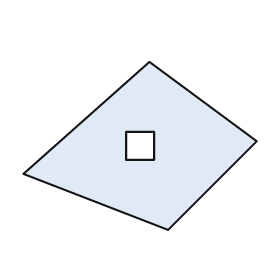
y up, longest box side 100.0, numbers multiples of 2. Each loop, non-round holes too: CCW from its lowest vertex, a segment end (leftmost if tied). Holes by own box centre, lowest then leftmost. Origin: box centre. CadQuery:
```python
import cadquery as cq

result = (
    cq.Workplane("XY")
    .moveTo(12.0, -36.0)
    .lineTo(50.0, 2.0)
    .lineTo(4.0, 36.0)
    .lineTo(-50.0, -12.0)
    .close()
    .moveTo(-6.0, -6.0)
    .lineTo(6.0, -6.0)
    .lineTo(6.0, 6.0)
    .lineTo(-6.0, 6.0)
    .close()
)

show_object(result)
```